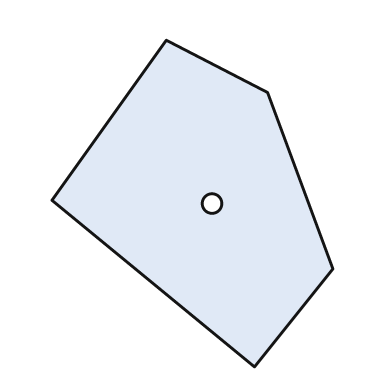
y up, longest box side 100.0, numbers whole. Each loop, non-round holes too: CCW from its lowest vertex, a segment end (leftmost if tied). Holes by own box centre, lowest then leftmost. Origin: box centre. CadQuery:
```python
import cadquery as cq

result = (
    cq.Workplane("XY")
    .moveTo(19.0, -50.0)
    .lineTo(43.0, -20.0)
    .lineTo(23.0, 34.0)
    .lineTo(-8.0, 50.0)
    .lineTo(-43.0, 1.0)
    .close()
    .moveTo(6.0, 0.0)
    .circle(3.0)
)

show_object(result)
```